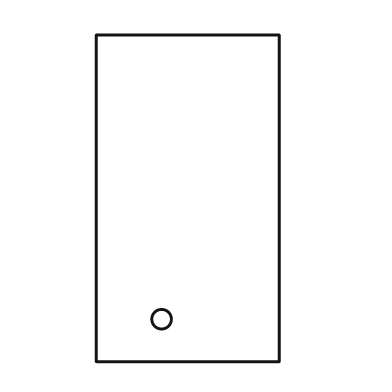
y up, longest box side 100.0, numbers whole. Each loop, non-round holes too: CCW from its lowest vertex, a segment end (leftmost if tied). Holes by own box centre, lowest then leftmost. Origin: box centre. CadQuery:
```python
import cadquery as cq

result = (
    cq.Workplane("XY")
    .moveTo(-28.0, -50.0)
    .lineTo(28.0, -50.0)
    .lineTo(28.0, 50.0)
    .lineTo(-28.0, 50.0)
    .close()
    .moveTo(-8.0, -37.0)
    .circle(3.0)
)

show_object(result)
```